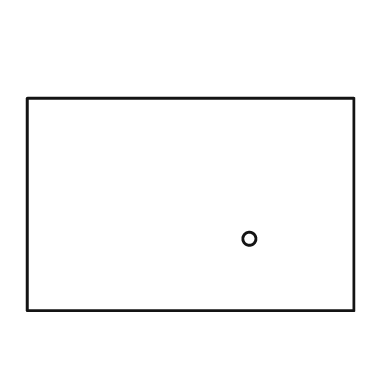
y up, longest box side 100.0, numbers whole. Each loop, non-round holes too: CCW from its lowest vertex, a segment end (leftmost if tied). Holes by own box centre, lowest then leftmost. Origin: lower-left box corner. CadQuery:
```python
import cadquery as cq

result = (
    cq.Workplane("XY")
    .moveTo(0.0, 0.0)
    .lineTo(100.0, 0.0)
    .lineTo(100.0, 65.0)
    .lineTo(0.0, 65.0)
    .close()
    .moveTo(68.0, 22.0)
    .circle(2.0)
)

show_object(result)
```